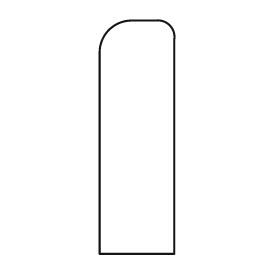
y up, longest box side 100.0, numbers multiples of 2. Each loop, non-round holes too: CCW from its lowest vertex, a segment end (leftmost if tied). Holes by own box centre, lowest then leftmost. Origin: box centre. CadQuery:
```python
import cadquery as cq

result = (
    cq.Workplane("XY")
    .moveTo(-16.0, -50.0)
    .lineTo(16.0, -50.0)
    .lineTo(16.0, 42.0)
    .threePointArc((14.0, 48.0), (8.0, 50.0))
    .lineTo(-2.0, 50.0)
    .threePointArc((-12.0, 46.0), (-16.0, 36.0))
    .close()
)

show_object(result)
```